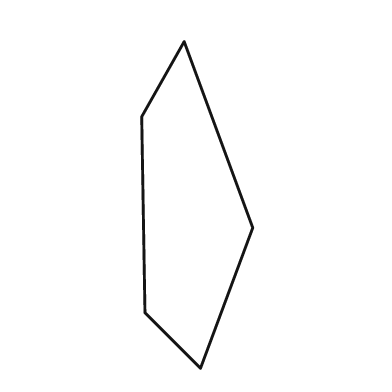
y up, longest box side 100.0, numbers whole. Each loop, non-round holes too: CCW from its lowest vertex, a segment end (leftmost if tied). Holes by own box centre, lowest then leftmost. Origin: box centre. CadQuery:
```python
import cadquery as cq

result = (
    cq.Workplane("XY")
    .moveTo(1.0, -50.0)
    .lineTo(17.0, -7.0)
    .lineTo(-4.0, 50.0)
    .lineTo(-17.0, 27.0)
    .lineTo(-16.0, -33.0)
    .close()
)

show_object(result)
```